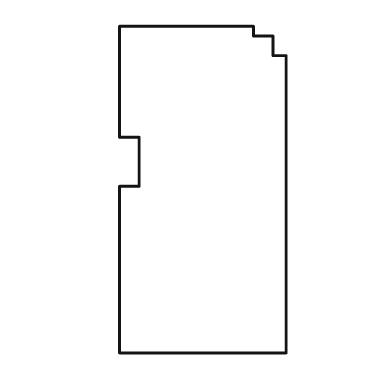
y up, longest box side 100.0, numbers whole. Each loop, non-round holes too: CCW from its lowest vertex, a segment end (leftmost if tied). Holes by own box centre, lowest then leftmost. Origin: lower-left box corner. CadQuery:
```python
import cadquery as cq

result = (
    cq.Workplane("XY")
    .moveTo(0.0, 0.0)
    .lineTo(51.0, 0.0)
    .lineTo(51.0, 91.0)
    .lineTo(47.0, 91.0)
    .lineTo(47.0, 97.0)
    .lineTo(41.0, 97.0)
    .lineTo(41.0, 100.0)
    .lineTo(0.0, 100.0)
    .lineTo(0.0, 66.0)
    .lineTo(6.0, 66.0)
    .lineTo(6.0, 51.0)
    .lineTo(0.0, 51.0)
    .close()
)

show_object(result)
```